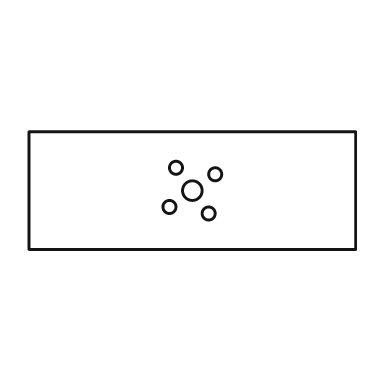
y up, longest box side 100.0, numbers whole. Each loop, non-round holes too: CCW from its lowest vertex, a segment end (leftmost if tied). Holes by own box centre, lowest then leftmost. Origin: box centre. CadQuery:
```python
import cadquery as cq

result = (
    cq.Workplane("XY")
    .moveTo(-50.0, -18.0)
    .lineTo(50.0, -18.0)
    .lineTo(50.0, 18.0)
    .lineTo(-50.0, 18.0)
    .close()
    .moveTo(5.0, -7.0)
    .circle(2.0)
    .moveTo(-7.0, -5.0)
    .circle(2.0)
    .moveTo(0.0, 0.0)
    .circle(3.0)
    .moveTo(7.0, 5.0)
    .circle(2.0)
    .moveTo(-5.0, 7.0)
    .circle(2.0)
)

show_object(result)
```